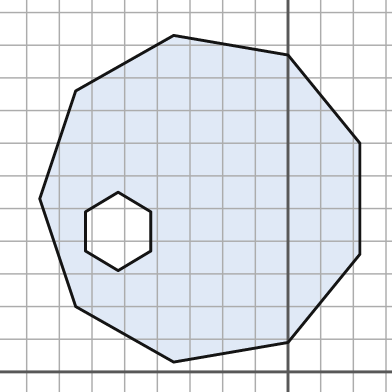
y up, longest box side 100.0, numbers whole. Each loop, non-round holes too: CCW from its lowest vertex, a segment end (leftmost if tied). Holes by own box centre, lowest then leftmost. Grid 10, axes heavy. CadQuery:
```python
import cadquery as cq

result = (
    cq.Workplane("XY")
    .moveTo(-35.0, 3.0)
    .lineTo(0.0, 9.0)
    .lineTo(22.0, 36.0)
    .lineTo(22.0, 70.0)
    .lineTo(0.0, 97.0)
    .lineTo(-35.0, 103.0)
    .lineTo(-65.0, 86.0)
    .lineTo(-76.0, 53.0)
    .lineTo(-65.0, 20.0)
    .close()
    .moveTo(-52.0, 31.0)
    .lineTo(-42.0, 37.0)
    .lineTo(-42.0, 49.0)
    .lineTo(-52.0, 55.0)
    .lineTo(-62.0, 49.0)
    .lineTo(-62.0, 37.0)
    .close()
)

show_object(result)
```